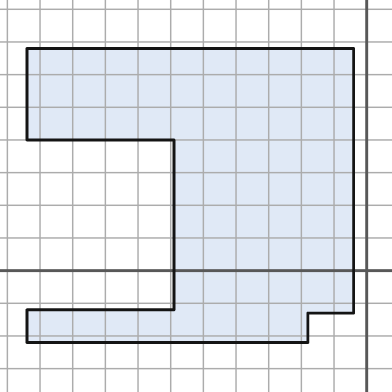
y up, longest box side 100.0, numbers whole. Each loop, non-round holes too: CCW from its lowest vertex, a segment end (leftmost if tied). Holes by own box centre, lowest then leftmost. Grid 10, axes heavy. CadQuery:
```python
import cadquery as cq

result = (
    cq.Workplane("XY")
    .moveTo(-104.0, -22.0)
    .lineTo(-18.0, -22.0)
    .lineTo(-18.0, -13.0)
    .lineTo(-4.0, -13.0)
    .lineTo(-4.0, 68.0)
    .lineTo(-104.0, 68.0)
    .lineTo(-104.0, 40.0)
    .lineTo(-59.0, 40.0)
    .lineTo(-59.0, -12.0)
    .lineTo(-104.0, -12.0)
    .close()
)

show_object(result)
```